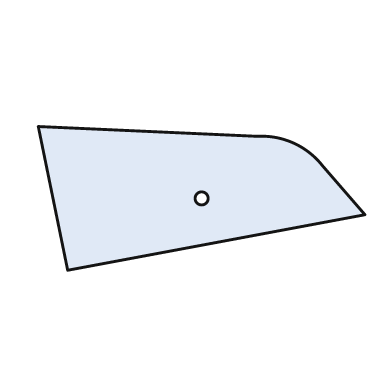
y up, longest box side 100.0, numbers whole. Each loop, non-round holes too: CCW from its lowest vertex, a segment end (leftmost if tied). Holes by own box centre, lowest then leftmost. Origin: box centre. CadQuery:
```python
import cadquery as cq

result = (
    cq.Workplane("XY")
    .moveTo(-41.0, -22.0)
    .lineTo(50.0, -5.0)
    .lineTo(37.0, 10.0)
    .threePointArc((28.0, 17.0), (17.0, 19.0))
    .lineTo(-50.0, 22.0)
    .close()
    .moveTo(0.0, 0.0)
    .circle(2.0)
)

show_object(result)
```